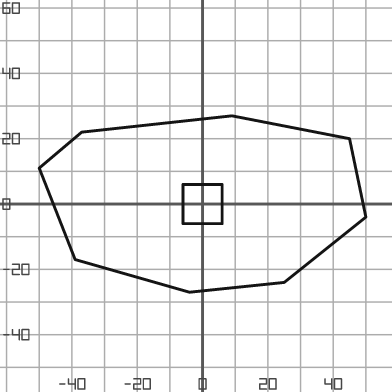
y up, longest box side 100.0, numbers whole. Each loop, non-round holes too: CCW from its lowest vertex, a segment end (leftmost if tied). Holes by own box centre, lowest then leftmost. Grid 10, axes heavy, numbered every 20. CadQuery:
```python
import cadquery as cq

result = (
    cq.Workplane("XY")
    .moveTo(-4.0, -27.0)
    .lineTo(25.0, -24.0)
    .lineTo(50.0, -4.0)
    .lineTo(45.0, 20.0)
    .lineTo(9.0, 27.0)
    .lineTo(-37.0, 22.0)
    .lineTo(-50.0, 11.0)
    .lineTo(-39.0, -17.0)
    .close()
    .moveTo(-6.0, -6.0)
    .lineTo(6.0, -6.0)
    .lineTo(6.0, 6.0)
    .lineTo(-6.0, 6.0)
    .close()
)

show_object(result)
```